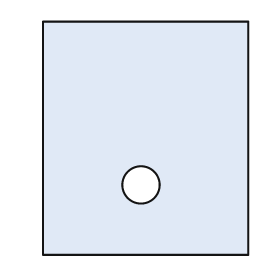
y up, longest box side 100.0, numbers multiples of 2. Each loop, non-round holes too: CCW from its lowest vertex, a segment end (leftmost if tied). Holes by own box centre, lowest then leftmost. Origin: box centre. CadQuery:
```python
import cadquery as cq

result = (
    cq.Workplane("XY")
    .moveTo(-44.0, -50.0)
    .lineTo(44.0, -50.0)
    .lineTo(44.0, 50.0)
    .lineTo(-44.0, 50.0)
    .close()
    .moveTo(-2.0, -20.0)
    .circle(8.0)
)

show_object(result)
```